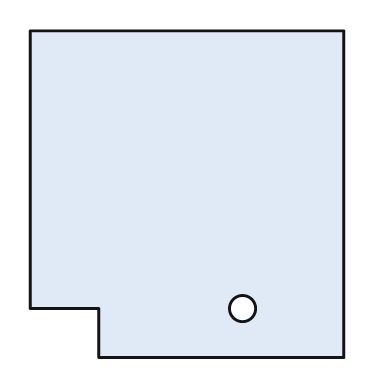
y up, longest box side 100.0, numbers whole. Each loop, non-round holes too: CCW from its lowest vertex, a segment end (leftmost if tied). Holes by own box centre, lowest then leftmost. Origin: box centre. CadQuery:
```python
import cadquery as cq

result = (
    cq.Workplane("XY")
    .moveTo(-27.0, -50.0)
    .lineTo(48.0, -50.0)
    .lineTo(48.0, 50.0)
    .lineTo(-48.0, 50.0)
    .lineTo(-48.0, -35.0)
    .lineTo(-27.0, -35.0)
    .close()
    .moveTo(17.0, -35.0)
    .circle(4.0)
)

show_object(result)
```